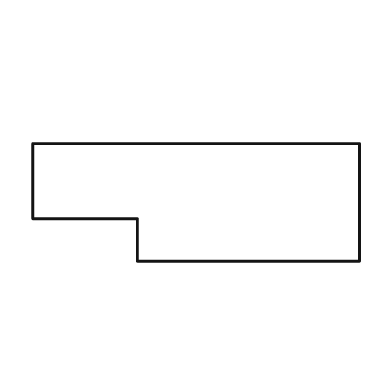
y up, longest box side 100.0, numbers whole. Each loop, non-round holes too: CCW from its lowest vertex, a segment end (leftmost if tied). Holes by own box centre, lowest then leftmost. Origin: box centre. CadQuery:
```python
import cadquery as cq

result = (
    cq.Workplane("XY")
    .moveTo(-18.0, -18.0)
    .lineTo(50.0, -18.0)
    .lineTo(50.0, 18.0)
    .lineTo(-50.0, 18.0)
    .lineTo(-50.0, -5.0)
    .lineTo(-18.0, -5.0)
    .close()
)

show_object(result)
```